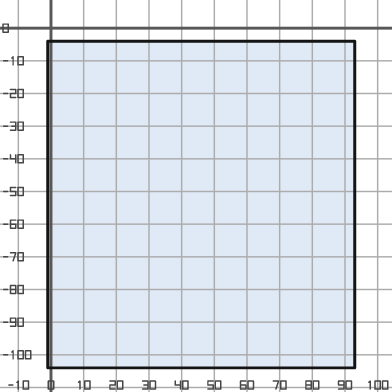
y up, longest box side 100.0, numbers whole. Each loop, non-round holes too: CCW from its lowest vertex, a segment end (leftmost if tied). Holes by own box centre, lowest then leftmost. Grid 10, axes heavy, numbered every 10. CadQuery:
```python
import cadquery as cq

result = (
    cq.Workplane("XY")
    .moveTo(-1.0, -104.0)
    .lineTo(93.0, -104.0)
    .lineTo(93.0, -4.0)
    .lineTo(-1.0, -4.0)
    .close()
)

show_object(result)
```